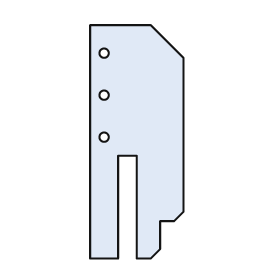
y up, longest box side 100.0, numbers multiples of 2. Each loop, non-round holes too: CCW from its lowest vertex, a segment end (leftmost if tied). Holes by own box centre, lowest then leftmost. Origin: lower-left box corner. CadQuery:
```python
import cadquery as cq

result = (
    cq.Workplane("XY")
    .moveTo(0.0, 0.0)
    .lineTo(12.0, 0.0)
    .lineTo(12.0, 44.0)
    .lineTo(20.0, 44.0)
    .lineTo(20.0, 0.0)
    .lineTo(26.0, 0.0)
    .lineTo(30.0, 4.0)
    .lineTo(30.0, 16.0)
    .lineTo(36.0, 16.0)
    .lineTo(40.0, 20.0)
    .lineTo(40.0, 86.0)
    .lineTo(26.0, 100.0)
    .lineTo(0.0, 100.0)
    .close()
    .moveTo(6.0, 52.0)
    .circle(2.0)
    .moveTo(6.0, 70.0)
    .circle(2.0)
    .moveTo(6.0, 88.0)
    .circle(2.0)
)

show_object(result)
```